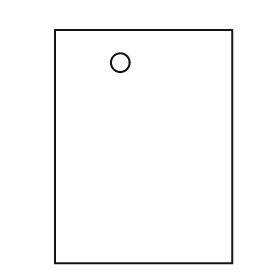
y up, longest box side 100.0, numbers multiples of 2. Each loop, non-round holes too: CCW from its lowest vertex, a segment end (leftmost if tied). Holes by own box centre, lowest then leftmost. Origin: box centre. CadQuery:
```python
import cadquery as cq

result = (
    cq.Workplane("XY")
    .moveTo(-38.0, -50.0)
    .lineTo(38.0, -50.0)
    .lineTo(38.0, 50.0)
    .lineTo(-38.0, 50.0)
    .close()
    .moveTo(-10.0, 36.0)
    .circle(4.0)
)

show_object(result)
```